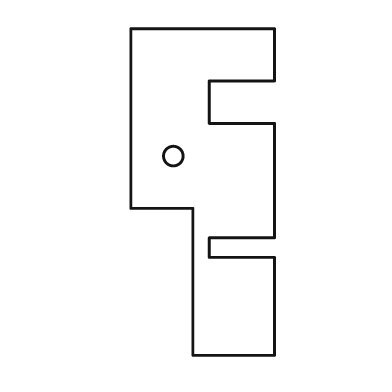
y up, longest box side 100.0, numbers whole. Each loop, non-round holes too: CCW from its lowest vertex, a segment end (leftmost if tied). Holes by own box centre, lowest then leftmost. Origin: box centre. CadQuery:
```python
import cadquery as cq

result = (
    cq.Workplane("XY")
    .moveTo(-3.0, -50.0)
    .lineTo(22.0, -50.0)
    .lineTo(22.0, -20.0)
    .lineTo(2.0, -20.0)
    .lineTo(2.0, -14.0)
    .lineTo(22.0, -14.0)
    .lineTo(22.0, 21.0)
    .lineTo(2.0, 21.0)
    .lineTo(2.0, 34.0)
    .lineTo(22.0, 34.0)
    .lineTo(22.0, 50.0)
    .lineTo(-22.0, 50.0)
    .lineTo(-22.0, -5.0)
    .lineTo(-3.0, -5.0)
    .close()
    .moveTo(-9.0, 11.0)
    .circle(3.0)
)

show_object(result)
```